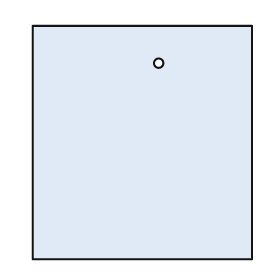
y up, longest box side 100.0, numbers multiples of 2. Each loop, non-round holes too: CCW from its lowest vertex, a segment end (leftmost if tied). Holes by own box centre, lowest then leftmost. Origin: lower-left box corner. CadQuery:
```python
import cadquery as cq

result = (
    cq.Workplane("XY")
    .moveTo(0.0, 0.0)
    .lineTo(94.0, 0.0)
    .lineTo(94.0, 100.0)
    .lineTo(0.0, 100.0)
    .close()
    .moveTo(54.0, 84.0)
    .circle(2.0)
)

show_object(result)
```